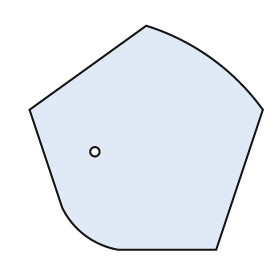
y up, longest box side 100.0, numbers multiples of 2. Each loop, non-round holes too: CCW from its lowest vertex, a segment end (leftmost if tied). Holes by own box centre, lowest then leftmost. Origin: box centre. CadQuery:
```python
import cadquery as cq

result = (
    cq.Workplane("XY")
    .moveTo(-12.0, -48.0)
    .lineTo(30.0, -48.0)
    .lineTo(50.0, 12.0)
    .threePointArc((28.0, 34.0), (0.0, 48.0))
    .lineTo(-50.0, 12.0)
    .lineTo(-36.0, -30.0)
    .threePointArc((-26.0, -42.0), (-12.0, -48.0))
    .close()
    .moveTo(-22.0, -6.0)
    .circle(2.0)
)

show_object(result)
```